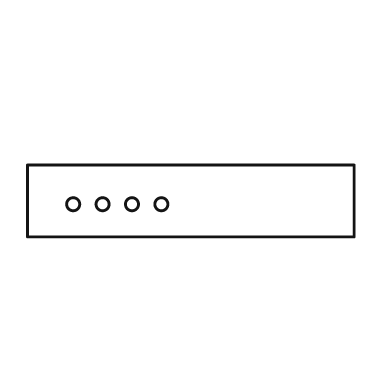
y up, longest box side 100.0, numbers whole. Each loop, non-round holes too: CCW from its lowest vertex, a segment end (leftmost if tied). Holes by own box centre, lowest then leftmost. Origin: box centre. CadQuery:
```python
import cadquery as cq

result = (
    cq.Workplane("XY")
    .moveTo(-50.0, -11.0)
    .lineTo(50.0, -11.0)
    .lineTo(50.0, 11.0)
    .lineTo(-50.0, 11.0)
    .close()
    .moveTo(-36.0, -1.0)
    .circle(2.0)
    .moveTo(-27.0, -1.0)
    .circle(2.0)
    .moveTo(-18.0, -1.0)
    .circle(2.0)
    .moveTo(-9.0, -1.0)
    .circle(2.0)
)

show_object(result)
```